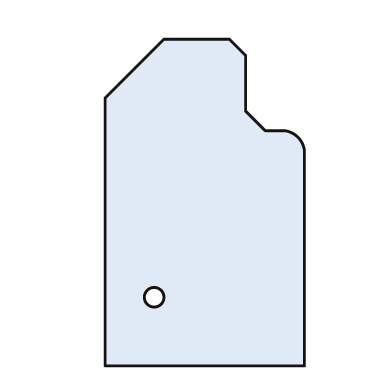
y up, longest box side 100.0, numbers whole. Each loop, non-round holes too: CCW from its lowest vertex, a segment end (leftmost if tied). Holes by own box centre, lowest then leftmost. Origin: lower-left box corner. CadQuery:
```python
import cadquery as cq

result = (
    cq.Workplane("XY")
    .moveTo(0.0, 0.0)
    .lineTo(61.0, 0.0)
    .lineTo(61.0, 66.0)
    .threePointArc((59.0, 70.0), (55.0, 72.0))
    .lineTo(49.0, 72.0)
    .lineTo(43.0, 78.0)
    .lineTo(43.0, 95.0)
    .lineTo(38.0, 100.0)
    .lineTo(18.0, 100.0)
    .lineTo(0.0, 82.0)
    .close()
    .moveTo(15.0, 21.0)
    .circle(3.0)
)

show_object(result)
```